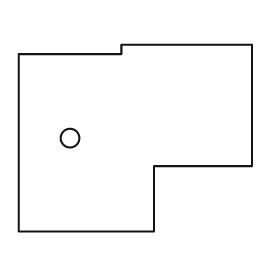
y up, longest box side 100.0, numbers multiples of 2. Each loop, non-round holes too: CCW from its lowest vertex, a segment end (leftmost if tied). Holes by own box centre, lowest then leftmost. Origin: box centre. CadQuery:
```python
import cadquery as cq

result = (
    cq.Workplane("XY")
    .moveTo(-50.0, -40.0)
    .lineTo(8.0, -40.0)
    .lineTo(8.0, -12.0)
    .lineTo(50.0, -12.0)
    .lineTo(50.0, 40.0)
    .lineTo(-6.0, 40.0)
    .lineTo(-6.0, 36.0)
    .lineTo(-50.0, 36.0)
    .close()
    .moveTo(-28.0, 0.0)
    .circle(4.0)
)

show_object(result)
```